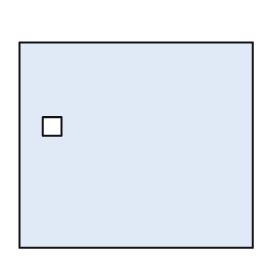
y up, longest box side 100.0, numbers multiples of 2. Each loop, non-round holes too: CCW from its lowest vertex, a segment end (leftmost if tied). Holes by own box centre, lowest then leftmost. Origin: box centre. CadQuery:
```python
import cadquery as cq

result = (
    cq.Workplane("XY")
    .moveTo(-50.0, -44.0)
    .lineTo(50.0, -44.0)
    .lineTo(50.0, 44.0)
    .lineTo(-50.0, 44.0)
    .close()
    .moveTo(-40.0, 4.0)
    .lineTo(-32.0, 4.0)
    .lineTo(-32.0, 12.0)
    .lineTo(-40.0, 12.0)
    .close()
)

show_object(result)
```